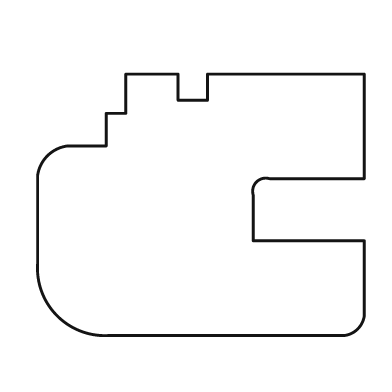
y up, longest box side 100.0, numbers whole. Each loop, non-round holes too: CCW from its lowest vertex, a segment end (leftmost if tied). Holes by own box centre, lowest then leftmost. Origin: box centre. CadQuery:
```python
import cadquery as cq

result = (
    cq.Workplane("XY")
    .moveTo(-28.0, -40.0)
    .lineTo(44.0, -40.0)
    .threePointArc((48.0, -38.0), (50.0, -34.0))
    .lineTo(50.0, -11.0)
    .lineTo(16.0, -11.0)
    .lineTo(16.0, 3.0)
    .threePointArc((17.0, 7.0), (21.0, 8.0))
    .lineTo(50.0, 8.0)
    .lineTo(50.0, 40.0)
    .lineTo(2.0, 40.0)
    .lineTo(2.0, 32.0)
    .lineTo(-7.0, 32.0)
    .lineTo(-7.0, 40.0)
    .lineTo(-23.0, 40.0)
    .lineTo(-23.0, 28.0)
    .lineTo(-29.0, 28.0)
    .lineTo(-29.0, 18.0)
    .lineTo(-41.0, 18.0)
    .threePointArc((-47.0, 15.0), (-50.0, 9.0))
    .lineTo(-50.0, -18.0)
    .threePointArc((-44.0, -34.0), (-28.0, -40.0))
    .close()
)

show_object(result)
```